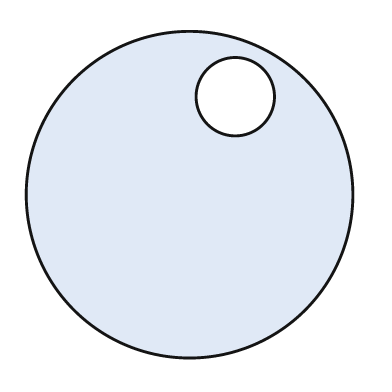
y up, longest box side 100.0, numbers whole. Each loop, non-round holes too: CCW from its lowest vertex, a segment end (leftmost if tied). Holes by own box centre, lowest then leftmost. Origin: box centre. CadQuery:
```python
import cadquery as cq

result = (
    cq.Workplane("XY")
    .moveTo(0.0, 0.0)
    .circle(50.0)
    .moveTo(14.0, 30.0)
    .circle(12.0)
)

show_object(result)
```